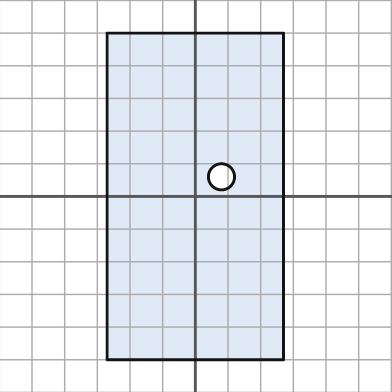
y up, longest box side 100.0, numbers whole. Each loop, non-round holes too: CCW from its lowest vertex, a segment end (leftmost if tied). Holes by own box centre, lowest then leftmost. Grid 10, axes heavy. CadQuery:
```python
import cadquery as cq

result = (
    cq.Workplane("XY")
    .moveTo(-27.0, -50.0)
    .lineTo(27.0, -50.0)
    .lineTo(27.0, 50.0)
    .lineTo(-27.0, 50.0)
    .close()
    .moveTo(8.0, 6.0)
    .circle(4.0)
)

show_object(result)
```